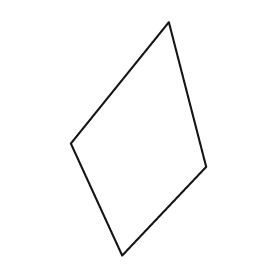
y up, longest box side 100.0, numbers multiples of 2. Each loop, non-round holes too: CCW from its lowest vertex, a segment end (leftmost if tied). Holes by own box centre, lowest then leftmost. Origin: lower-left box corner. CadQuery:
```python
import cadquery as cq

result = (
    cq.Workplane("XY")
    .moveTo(22.0, 0.0)
    .lineTo(58.0, 38.0)
    .lineTo(42.0, 100.0)
    .lineTo(0.0, 48.0)
    .close()
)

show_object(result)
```